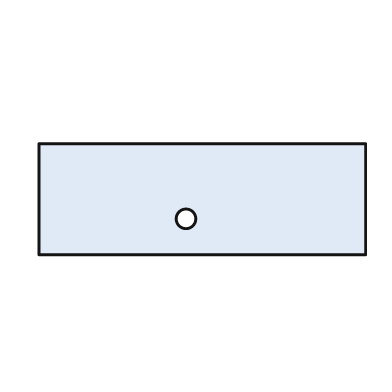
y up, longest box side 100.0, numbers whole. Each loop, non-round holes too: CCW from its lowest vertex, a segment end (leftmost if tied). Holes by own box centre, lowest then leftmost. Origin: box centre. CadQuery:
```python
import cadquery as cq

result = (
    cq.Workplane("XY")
    .moveTo(-50.0, -17.0)
    .lineTo(50.0, -17.0)
    .lineTo(50.0, 17.0)
    .lineTo(-50.0, 17.0)
    .close()
    .moveTo(-5.0, -6.0)
    .circle(3.0)
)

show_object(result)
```